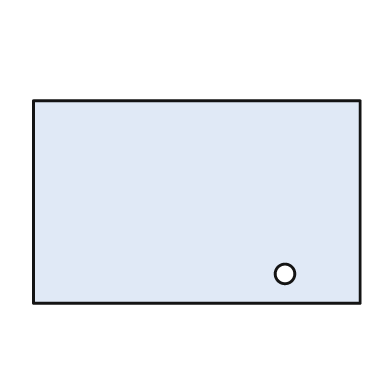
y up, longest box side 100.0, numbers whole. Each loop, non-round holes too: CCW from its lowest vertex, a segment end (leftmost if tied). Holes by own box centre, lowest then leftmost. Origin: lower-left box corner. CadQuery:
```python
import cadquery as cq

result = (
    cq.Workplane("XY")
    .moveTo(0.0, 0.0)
    .lineTo(100.0, 0.0)
    .lineTo(100.0, 62.0)
    .lineTo(0.0, 62.0)
    .close()
    .moveTo(77.0, 9.0)
    .circle(3.0)
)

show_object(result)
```